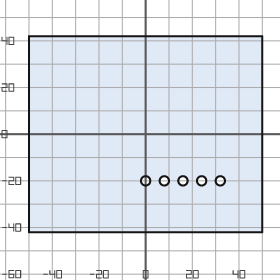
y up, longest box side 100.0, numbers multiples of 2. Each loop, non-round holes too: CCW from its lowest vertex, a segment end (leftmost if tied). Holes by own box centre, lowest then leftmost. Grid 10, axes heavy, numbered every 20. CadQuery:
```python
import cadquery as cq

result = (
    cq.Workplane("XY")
    .moveTo(-50.0, -42.0)
    .lineTo(50.0, -42.0)
    .lineTo(50.0, 42.0)
    .lineTo(-50.0, 42.0)
    .close()
    .moveTo(0.0, -20.0)
    .circle(2.0)
    .moveTo(8.0, -20.0)
    .circle(2.0)
    .moveTo(16.0, -20.0)
    .circle(2.0)
    .moveTo(24.0, -20.0)
    .circle(2.0)
    .moveTo(32.0, -20.0)
    .circle(2.0)
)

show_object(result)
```